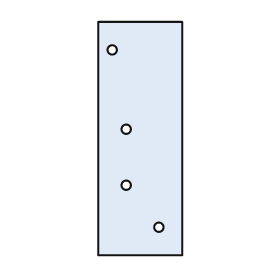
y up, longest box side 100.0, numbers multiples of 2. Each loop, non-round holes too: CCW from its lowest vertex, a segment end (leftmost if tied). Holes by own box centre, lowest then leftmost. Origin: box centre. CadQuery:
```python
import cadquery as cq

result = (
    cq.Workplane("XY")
    .moveTo(-18.0, -50.0)
    .lineTo(18.0, -50.0)
    .lineTo(18.0, 50.0)
    .lineTo(-18.0, 50.0)
    .close()
    .moveTo(8.0, -38.0)
    .circle(2.0)
    .moveTo(-6.0, -20.0)
    .circle(2.0)
    .moveTo(-6.0, 4.0)
    .circle(2.0)
    .moveTo(-12.0, 38.0)
    .circle(2.0)
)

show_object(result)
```